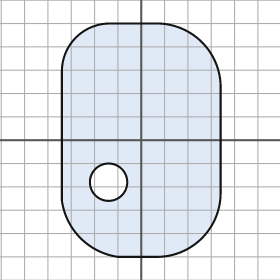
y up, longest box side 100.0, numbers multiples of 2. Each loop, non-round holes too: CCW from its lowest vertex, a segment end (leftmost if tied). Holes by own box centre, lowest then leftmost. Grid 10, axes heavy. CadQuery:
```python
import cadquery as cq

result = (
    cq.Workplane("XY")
    .moveTo(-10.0, -50.0)
    .lineTo(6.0, -50.0)
    .threePointArc((26.0, -42.0), (34.0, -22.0))
    .lineTo(34.0, 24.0)
    .threePointArc((26.0, 42.0), (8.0, 50.0))
    .lineTo(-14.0, 50.0)
    .threePointArc((-28.0, 44.0), (-34.0, 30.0))
    .lineTo(-34.0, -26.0)
    .threePointArc((-26.0, -42.0), (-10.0, -50.0))
    .close()
    .moveTo(-14.0, -18.0)
    .circle(8.0)
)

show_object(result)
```